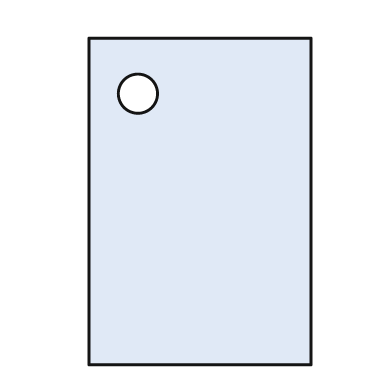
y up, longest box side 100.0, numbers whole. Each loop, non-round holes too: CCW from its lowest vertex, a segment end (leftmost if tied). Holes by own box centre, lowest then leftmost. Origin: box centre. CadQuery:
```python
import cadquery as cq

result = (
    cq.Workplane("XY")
    .moveTo(-34.0, -50.0)
    .lineTo(34.0, -50.0)
    .lineTo(34.0, 50.0)
    .lineTo(-34.0, 50.0)
    .close()
    .moveTo(-19.0, 33.0)
    .circle(6.0)
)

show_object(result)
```